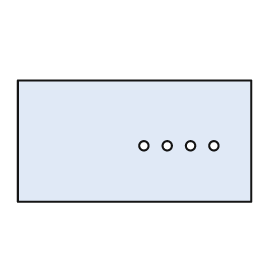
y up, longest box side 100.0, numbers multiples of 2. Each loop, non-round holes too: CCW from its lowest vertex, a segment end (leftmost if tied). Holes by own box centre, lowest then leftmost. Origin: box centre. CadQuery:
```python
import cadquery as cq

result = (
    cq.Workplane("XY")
    .moveTo(-50.0, -26.0)
    .lineTo(50.0, -26.0)
    .lineTo(50.0, 26.0)
    .lineTo(-50.0, 26.0)
    .close()
    .moveTo(4.0, -2.0)
    .circle(2.0)
    .moveTo(14.0, -2.0)
    .circle(2.0)
    .moveTo(24.0, -2.0)
    .circle(2.0)
    .moveTo(34.0, -2.0)
    .circle(2.0)
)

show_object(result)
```